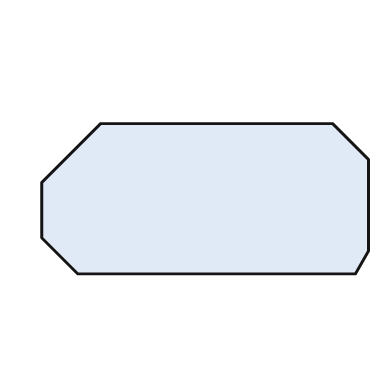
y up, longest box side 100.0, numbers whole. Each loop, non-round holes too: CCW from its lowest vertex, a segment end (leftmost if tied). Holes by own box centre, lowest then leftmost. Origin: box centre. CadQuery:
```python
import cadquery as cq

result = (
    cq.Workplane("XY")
    .moveTo(-39.0, -23.0)
    .lineTo(46.0, -23.0)
    .lineTo(50.0, -16.0)
    .lineTo(50.0, 12.0)
    .lineTo(39.0, 23.0)
    .lineTo(-32.0, 23.0)
    .lineTo(-50.0, 5.0)
    .lineTo(-50.0, -12.0)
    .close()
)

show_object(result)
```